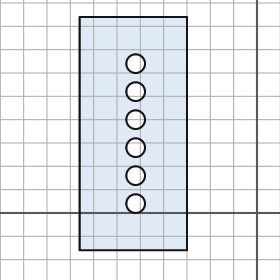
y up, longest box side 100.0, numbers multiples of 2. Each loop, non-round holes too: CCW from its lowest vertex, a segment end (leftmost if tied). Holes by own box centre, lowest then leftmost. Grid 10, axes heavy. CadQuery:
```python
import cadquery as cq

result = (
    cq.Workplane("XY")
    .moveTo(-76.0, -16.0)
    .lineTo(-30.0, -16.0)
    .lineTo(-30.0, 84.0)
    .lineTo(-76.0, 84.0)
    .close()
    .moveTo(-52.0, 4.0)
    .circle(4.0)
    .moveTo(-52.0, 16.0)
    .circle(4.0)
    .moveTo(-52.0, 28.0)
    .circle(4.0)
    .moveTo(-52.0, 40.0)
    .circle(4.0)
    .moveTo(-52.0, 52.0)
    .circle(4.0)
    .moveTo(-52.0, 64.0)
    .circle(4.0)
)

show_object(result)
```